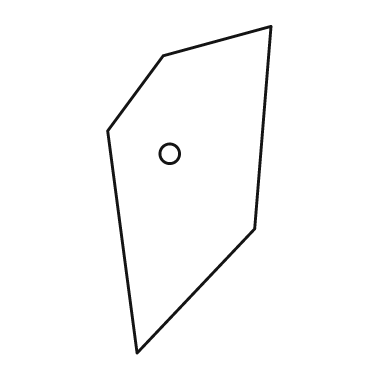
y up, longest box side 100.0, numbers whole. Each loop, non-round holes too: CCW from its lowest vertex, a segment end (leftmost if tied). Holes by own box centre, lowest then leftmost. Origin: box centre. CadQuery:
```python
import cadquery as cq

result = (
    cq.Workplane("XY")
    .moveTo(-16.0, -50.0)
    .lineTo(20.0, -12.0)
    .lineTo(25.0, 50.0)
    .lineTo(-8.0, 41.0)
    .lineTo(-25.0, 18.0)
    .close()
    .moveTo(-6.0, 11.0)
    .circle(3.0)
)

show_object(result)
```